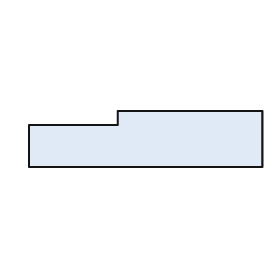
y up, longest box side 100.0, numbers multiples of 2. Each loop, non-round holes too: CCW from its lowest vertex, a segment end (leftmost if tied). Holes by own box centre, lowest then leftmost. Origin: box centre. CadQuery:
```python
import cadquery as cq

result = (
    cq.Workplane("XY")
    .moveTo(-50.0, -12.0)
    .lineTo(50.0, -12.0)
    .lineTo(50.0, 12.0)
    .lineTo(-12.0, 12.0)
    .lineTo(-12.0, 6.0)
    .lineTo(-50.0, 6.0)
    .close()
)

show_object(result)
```